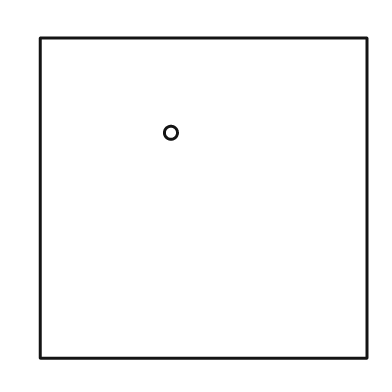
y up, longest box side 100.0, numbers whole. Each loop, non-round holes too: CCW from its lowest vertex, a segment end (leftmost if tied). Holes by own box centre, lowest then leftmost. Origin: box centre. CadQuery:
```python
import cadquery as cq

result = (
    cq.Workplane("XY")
    .moveTo(-50.0, -49.0)
    .lineTo(50.0, -49.0)
    .lineTo(50.0, 49.0)
    .lineTo(-50.0, 49.0)
    .close()
    .moveTo(-10.0, 20.0)
    .circle(2.0)
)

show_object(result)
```